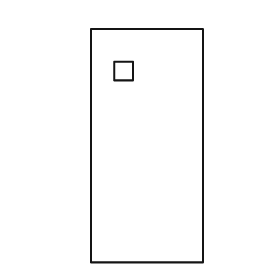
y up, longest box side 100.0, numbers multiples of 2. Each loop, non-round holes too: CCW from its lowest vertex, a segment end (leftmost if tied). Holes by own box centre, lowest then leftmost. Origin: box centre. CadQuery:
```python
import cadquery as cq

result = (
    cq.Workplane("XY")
    .moveTo(-24.0, -50.0)
    .lineTo(24.0, -50.0)
    .lineTo(24.0, 50.0)
    .lineTo(-24.0, 50.0)
    .close()
    .moveTo(-14.0, 28.0)
    .lineTo(-6.0, 28.0)
    .lineTo(-6.0, 36.0)
    .lineTo(-14.0, 36.0)
    .close()
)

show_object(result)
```